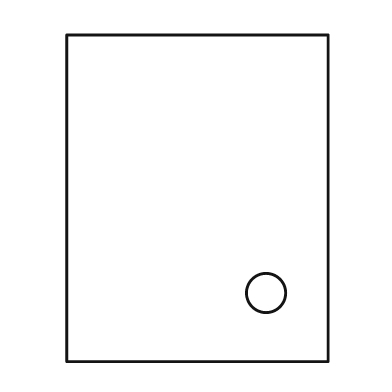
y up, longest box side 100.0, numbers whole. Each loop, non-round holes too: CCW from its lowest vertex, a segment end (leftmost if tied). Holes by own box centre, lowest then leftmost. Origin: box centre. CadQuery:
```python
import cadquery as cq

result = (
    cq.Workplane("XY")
    .moveTo(-40.0, -50.0)
    .lineTo(40.0, -50.0)
    .lineTo(40.0, 50.0)
    .lineTo(-40.0, 50.0)
    .close()
    .moveTo(21.0, -29.0)
    .circle(6.0)
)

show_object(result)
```